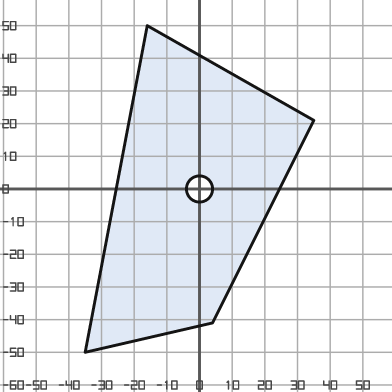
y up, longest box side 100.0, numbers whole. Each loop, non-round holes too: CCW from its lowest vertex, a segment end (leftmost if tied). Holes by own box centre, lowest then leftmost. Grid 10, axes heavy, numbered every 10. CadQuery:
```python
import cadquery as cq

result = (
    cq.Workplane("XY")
    .moveTo(-35.0, -50.0)
    .lineTo(4.0, -41.0)
    .lineTo(35.0, 21.0)
    .lineTo(-16.0, 50.0)
    .close()
    .moveTo(0.0, 0.0)
    .circle(4.0)
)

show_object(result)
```